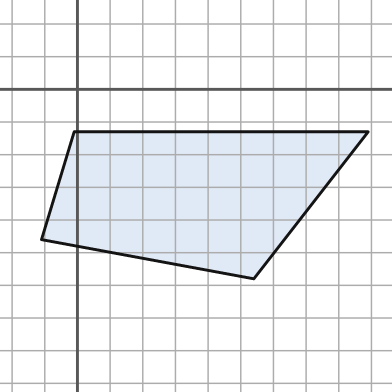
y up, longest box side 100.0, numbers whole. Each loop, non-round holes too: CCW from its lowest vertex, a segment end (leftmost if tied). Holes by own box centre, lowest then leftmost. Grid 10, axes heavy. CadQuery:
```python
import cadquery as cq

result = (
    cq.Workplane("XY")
    .moveTo(54.0, -58.0)
    .lineTo(89.0, -13.0)
    .lineTo(-1.0, -13.0)
    .lineTo(-11.0, -46.0)
    .close()
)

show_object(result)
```